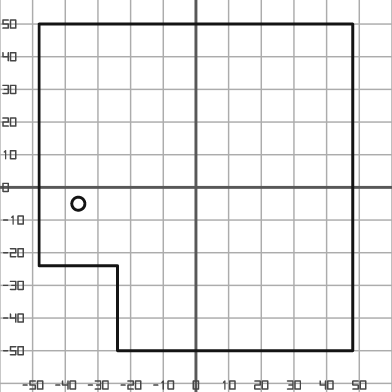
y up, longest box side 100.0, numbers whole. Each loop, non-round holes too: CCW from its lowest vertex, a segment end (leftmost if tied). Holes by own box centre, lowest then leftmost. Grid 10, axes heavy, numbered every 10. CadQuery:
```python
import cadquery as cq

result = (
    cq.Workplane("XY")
    .moveTo(-24.0, -50.0)
    .lineTo(48.0, -50.0)
    .lineTo(48.0, 50.0)
    .lineTo(-48.0, 50.0)
    .lineTo(-48.0, -24.0)
    .lineTo(-24.0, -24.0)
    .close()
    .moveTo(-36.0, -5.0)
    .circle(2.0)
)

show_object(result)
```